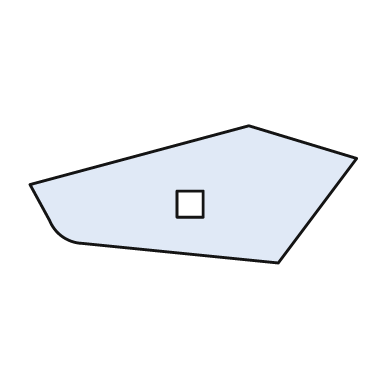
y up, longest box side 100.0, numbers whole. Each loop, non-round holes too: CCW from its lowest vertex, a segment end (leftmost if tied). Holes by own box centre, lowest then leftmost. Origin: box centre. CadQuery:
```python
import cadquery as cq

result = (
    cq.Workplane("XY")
    .moveTo(26.0, -21.0)
    .lineTo(50.0, 11.0)
    .lineTo(17.0, 21.0)
    .lineTo(-50.0, 3.0)
    .lineTo(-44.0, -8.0)
    .threePointArc((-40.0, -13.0), (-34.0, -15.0))
    .close()
    .moveTo(-5.0, -7.0)
    .lineTo(3.0, -7.0)
    .lineTo(3.0, 1.0)
    .lineTo(-5.0, 1.0)
    .close()
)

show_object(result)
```